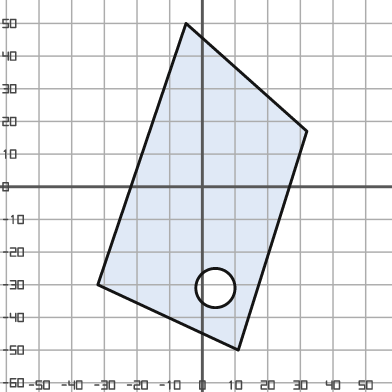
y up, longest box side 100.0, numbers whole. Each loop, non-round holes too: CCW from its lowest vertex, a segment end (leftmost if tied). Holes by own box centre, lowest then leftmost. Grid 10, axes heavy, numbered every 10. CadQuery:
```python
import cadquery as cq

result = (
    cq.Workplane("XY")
    .moveTo(11.0, -50.0)
    .lineTo(32.0, 17.0)
    .lineTo(-5.0, 50.0)
    .lineTo(-32.0, -30.0)
    .close()
    .moveTo(4.0, -31.0)
    .circle(6.0)
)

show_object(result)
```